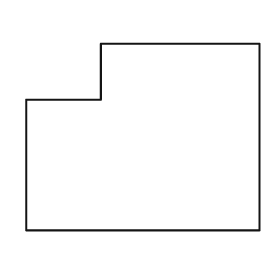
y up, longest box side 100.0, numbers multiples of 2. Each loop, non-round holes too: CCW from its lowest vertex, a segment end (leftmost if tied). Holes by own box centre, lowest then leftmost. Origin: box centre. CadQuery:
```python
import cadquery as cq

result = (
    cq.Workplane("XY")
    .moveTo(-50.0, -40.0)
    .lineTo(50.0, -40.0)
    .lineTo(50.0, 40.0)
    .lineTo(-18.0, 40.0)
    .lineTo(-18.0, 16.0)
    .lineTo(-50.0, 16.0)
    .close()
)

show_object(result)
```